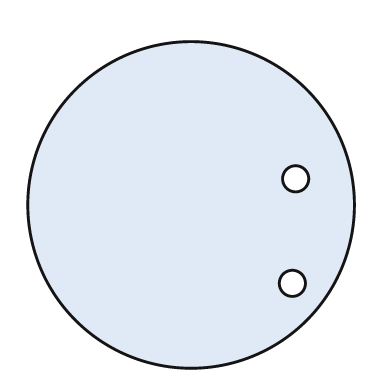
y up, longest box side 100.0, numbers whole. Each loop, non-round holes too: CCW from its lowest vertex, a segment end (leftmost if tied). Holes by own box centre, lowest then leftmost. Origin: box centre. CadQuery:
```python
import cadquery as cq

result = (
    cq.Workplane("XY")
    .moveTo(0.0, 0.0)
    .circle(50.0)
    .moveTo(31.0, -24.0)
    .circle(4.0)
    .moveTo(32.0, 8.0)
    .circle(4.0)
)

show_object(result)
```